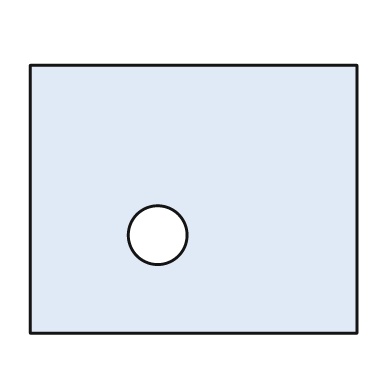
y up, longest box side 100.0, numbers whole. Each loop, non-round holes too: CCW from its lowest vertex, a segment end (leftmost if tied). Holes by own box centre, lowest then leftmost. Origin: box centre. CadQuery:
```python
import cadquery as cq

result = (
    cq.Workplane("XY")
    .moveTo(-50.0, -41.0)
    .lineTo(50.0, -41.0)
    .lineTo(50.0, 41.0)
    .lineTo(-50.0, 41.0)
    .close()
    .moveTo(-11.0, -11.0)
    .circle(9.0)
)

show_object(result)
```